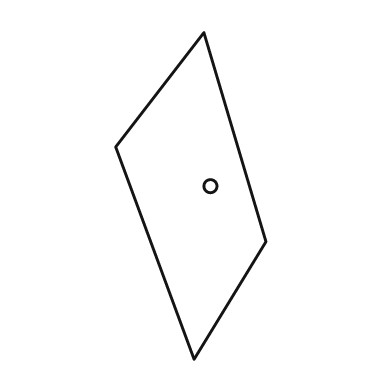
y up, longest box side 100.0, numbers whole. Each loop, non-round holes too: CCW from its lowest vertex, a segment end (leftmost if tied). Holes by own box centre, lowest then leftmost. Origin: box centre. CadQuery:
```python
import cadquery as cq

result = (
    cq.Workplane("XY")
    .moveTo(1.0, -50.0)
    .lineTo(23.0, -14.0)
    .lineTo(4.0, 50.0)
    .lineTo(-23.0, 15.0)
    .close()
    .moveTo(6.0, 3.0)
    .circle(2.0)
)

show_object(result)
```